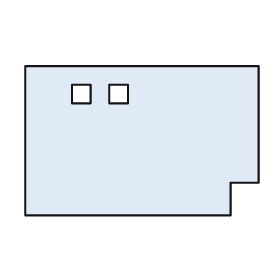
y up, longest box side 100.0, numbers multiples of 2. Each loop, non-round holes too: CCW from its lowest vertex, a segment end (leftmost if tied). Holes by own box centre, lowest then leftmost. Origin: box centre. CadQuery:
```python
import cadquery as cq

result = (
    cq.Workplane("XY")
    .moveTo(-50.0, -32.0)
    .lineTo(38.0, -32.0)
    .lineTo(38.0, -18.0)
    .lineTo(50.0, -18.0)
    .lineTo(50.0, 32.0)
    .lineTo(-50.0, 32.0)
    .close()
    .moveTo(-30.0, 16.0)
    .lineTo(-22.0, 16.0)
    .lineTo(-22.0, 24.0)
    .lineTo(-30.0, 24.0)
    .close()
    .moveTo(-14.0, 16.0)
    .lineTo(-6.0, 16.0)
    .lineTo(-6.0, 24.0)
    .lineTo(-14.0, 24.0)
    .close()
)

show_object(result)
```